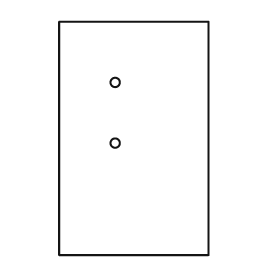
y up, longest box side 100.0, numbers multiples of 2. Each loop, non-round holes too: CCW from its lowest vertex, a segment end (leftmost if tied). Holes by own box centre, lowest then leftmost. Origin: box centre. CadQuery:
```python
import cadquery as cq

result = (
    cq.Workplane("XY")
    .moveTo(-32.0, -50.0)
    .lineTo(32.0, -50.0)
    .lineTo(32.0, 50.0)
    .lineTo(-32.0, 50.0)
    .close()
    .moveTo(-8.0, -2.0)
    .circle(2.0)
    .moveTo(-8.0, 24.0)
    .circle(2.0)
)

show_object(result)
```